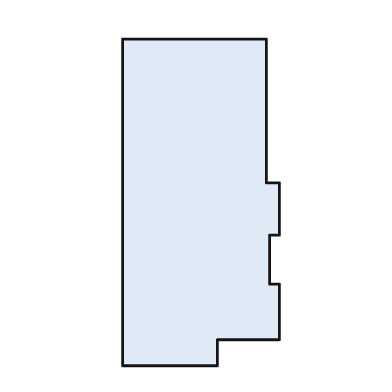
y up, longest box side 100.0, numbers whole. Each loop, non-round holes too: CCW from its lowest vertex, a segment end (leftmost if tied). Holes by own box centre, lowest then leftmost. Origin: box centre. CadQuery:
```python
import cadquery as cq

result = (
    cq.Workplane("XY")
    .moveTo(-24.0, -50.0)
    .lineTo(5.0, -50.0)
    .lineTo(5.0, -42.0)
    .lineTo(24.0, -42.0)
    .lineTo(24.0, -25.0)
    .lineTo(21.0, -25.0)
    .lineTo(21.0, -10.0)
    .lineTo(24.0, -10.0)
    .lineTo(24.0, 6.0)
    .lineTo(20.0, 6.0)
    .lineTo(20.0, 50.0)
    .lineTo(-24.0, 50.0)
    .close()
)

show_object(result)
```